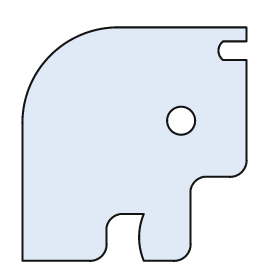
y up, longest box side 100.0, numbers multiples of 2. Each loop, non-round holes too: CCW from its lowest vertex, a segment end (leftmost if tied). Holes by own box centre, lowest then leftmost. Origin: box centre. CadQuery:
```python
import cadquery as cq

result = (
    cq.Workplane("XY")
    .moveTo(-48.0, -50.0)
    .lineTo(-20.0, -50.0)
    .threePointArc((-14.0, -48.0), (-12.0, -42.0))
    .lineTo(-12.0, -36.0)
    .threePointArc((-10.0, -32.0), (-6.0, -30.0))
    .lineTo(4.0, -30.0)
    .threePointArc((2.0, -40.0), (4.0, -50.0))
    .lineTo(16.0, -50.0)
    .threePointArc((22.0, -48.0), (24.0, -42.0))
    .lineTo(24.0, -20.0)
    .threePointArc((26.0, -16.0), (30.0, -14.0))
    .lineTo(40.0, -14.0)
    .threePointArc((46.0, -12.0), (48.0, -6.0))
    .lineTo(48.0, 36.0)
    .lineTo(38.0, 36.0)
    .threePointArc((36.0, 40.0), (38.0, 44.0))
    .lineTo(48.0, 44.0)
    .lineTo(48.0, 50.0)
    .lineTo(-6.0, 50.0)
    .threePointArc((-36.0, 38.0), (-48.0, 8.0))
    .close()
    .moveTo(20.0, 10.0)
    .circle(6.0)
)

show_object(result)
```